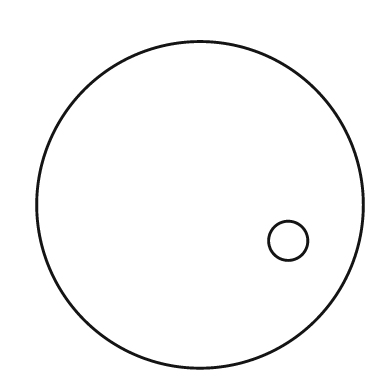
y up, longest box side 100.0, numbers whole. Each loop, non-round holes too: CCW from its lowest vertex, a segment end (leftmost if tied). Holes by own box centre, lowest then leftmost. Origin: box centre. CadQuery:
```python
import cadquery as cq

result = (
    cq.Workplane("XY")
    .moveTo(0.0, 0.0)
    .circle(50.0)
    .moveTo(27.0, -11.0)
    .circle(6.0)
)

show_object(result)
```